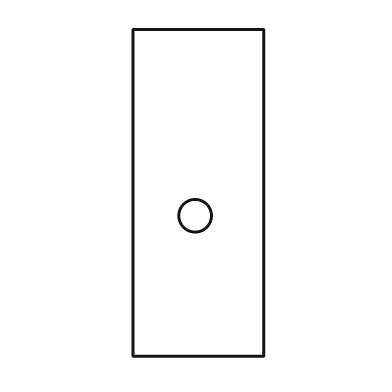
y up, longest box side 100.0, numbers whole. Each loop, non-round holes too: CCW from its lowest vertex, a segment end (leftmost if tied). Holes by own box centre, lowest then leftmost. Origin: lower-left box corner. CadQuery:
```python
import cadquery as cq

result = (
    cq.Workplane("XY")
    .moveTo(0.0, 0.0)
    .lineTo(40.0, 0.0)
    .lineTo(40.0, 100.0)
    .lineTo(0.0, 100.0)
    .close()
    .moveTo(19.0, 43.0)
    .circle(5.0)
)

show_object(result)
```